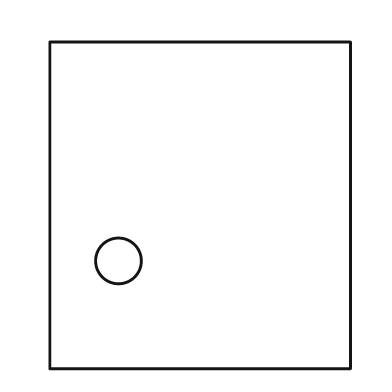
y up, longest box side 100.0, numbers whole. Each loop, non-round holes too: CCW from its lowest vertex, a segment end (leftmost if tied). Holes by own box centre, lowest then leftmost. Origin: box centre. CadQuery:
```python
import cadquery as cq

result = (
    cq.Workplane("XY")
    .moveTo(-46.0, -50.0)
    .lineTo(46.0, -50.0)
    .lineTo(46.0, 50.0)
    .lineTo(-46.0, 50.0)
    .close()
    .moveTo(-25.0, -17.0)
    .circle(7.0)
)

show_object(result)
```